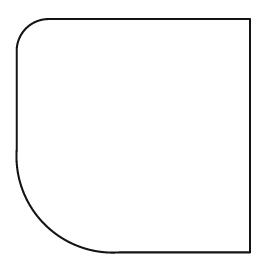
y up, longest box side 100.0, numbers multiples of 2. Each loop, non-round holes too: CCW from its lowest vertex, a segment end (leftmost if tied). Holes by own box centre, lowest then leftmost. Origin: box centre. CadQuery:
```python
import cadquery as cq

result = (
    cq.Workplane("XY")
    .moveTo(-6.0, -50.0)
    .lineTo(50.0, -50.0)
    .lineTo(50.0, 50.0)
    .lineTo(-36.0, 50.0)
    .threePointArc((-46.0, 46.0), (-50.0, 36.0))
    .lineTo(-50.0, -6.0)
    .threePointArc((-38.0, -38.0), (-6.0, -50.0))
    .close()
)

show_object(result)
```